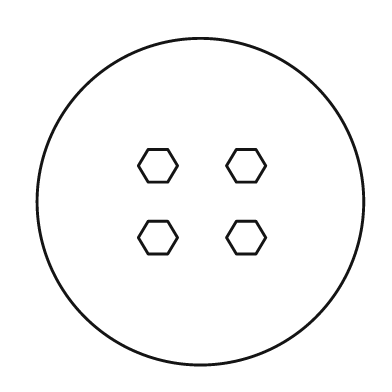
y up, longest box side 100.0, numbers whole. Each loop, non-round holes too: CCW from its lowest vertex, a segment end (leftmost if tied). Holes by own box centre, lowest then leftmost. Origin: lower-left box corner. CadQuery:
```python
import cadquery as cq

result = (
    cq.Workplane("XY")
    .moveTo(50.0, 50.0)
    .circle(50.0)
    .moveTo(34.0, 34.0)
    .lineTo(40.0, 34.0)
    .lineTo(43.0, 39.0)
    .lineTo(40.0, 44.0)
    .lineTo(34.0, 44.0)
    .lineTo(31.0, 39.0)
    .close()
    .moveTo(61.0, 34.0)
    .lineTo(67.0, 34.0)
    .lineTo(70.0, 39.0)
    .lineTo(67.0, 44.0)
    .lineTo(61.0, 44.0)
    .lineTo(58.0, 39.0)
    .close()
    .moveTo(34.0, 56.0)
    .lineTo(40.0, 56.0)
    .lineTo(43.0, 61.0)
    .lineTo(40.0, 66.0)
    .lineTo(34.0, 66.0)
    .lineTo(31.0, 61.0)
    .close()
    .moveTo(61.0, 56.0)
    .lineTo(67.0, 56.0)
    .lineTo(70.0, 61.0)
    .lineTo(67.0, 66.0)
    .lineTo(61.0, 66.0)
    .lineTo(58.0, 61.0)
    .close()
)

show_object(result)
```